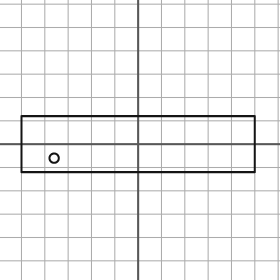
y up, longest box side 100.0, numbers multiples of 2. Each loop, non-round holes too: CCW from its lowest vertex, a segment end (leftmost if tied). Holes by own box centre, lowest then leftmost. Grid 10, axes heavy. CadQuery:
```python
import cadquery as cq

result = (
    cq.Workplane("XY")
    .moveTo(-50.0, -12.0)
    .lineTo(50.0, -12.0)
    .lineTo(50.0, 12.0)
    .lineTo(-50.0, 12.0)
    .close()
    .moveTo(-36.0, -6.0)
    .circle(2.0)
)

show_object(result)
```